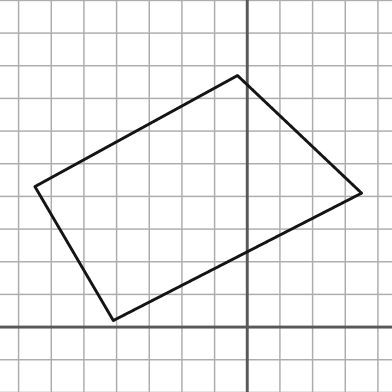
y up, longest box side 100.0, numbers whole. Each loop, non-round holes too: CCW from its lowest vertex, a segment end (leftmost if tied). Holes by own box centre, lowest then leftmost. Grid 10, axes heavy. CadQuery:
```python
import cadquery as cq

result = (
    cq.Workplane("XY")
    .moveTo(-41.0, 2.0)
    .lineTo(35.0, 41.0)
    .lineTo(-3.0, 77.0)
    .lineTo(-65.0, 43.0)
    .close()
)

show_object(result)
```